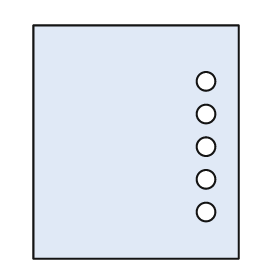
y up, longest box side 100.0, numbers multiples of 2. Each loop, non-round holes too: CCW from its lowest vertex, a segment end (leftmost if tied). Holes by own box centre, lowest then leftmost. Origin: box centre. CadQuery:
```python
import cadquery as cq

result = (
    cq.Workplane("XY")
    .moveTo(-44.0, -50.0)
    .lineTo(44.0, -50.0)
    .lineTo(44.0, 50.0)
    .lineTo(-44.0, 50.0)
    .close()
    .moveTo(30.0, -30.0)
    .circle(4.0)
    .moveTo(30.0, -16.0)
    .circle(4.0)
    .moveTo(30.0, -2.0)
    .circle(4.0)
    .moveTo(30.0, 12.0)
    .circle(4.0)
    .moveTo(30.0, 26.0)
    .circle(4.0)
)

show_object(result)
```